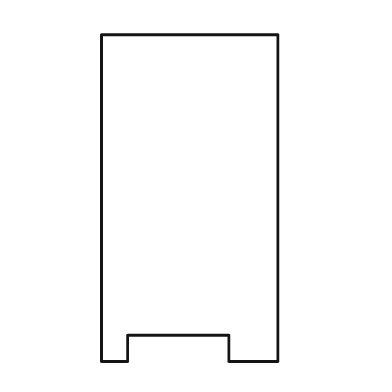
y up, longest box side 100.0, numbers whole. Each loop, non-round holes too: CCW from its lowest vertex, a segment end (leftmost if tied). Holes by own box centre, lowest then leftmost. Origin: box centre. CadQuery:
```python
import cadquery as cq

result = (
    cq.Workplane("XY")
    .moveTo(-27.0, -50.0)
    .lineTo(-19.0, -50.0)
    .lineTo(-19.0, -42.0)
    .lineTo(12.0, -42.0)
    .lineTo(12.0, -50.0)
    .lineTo(27.0, -50.0)
    .lineTo(27.0, 50.0)
    .lineTo(-27.0, 50.0)
    .close()
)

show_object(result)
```